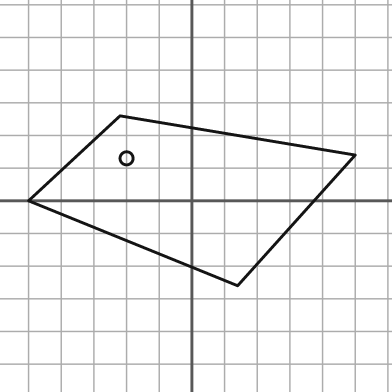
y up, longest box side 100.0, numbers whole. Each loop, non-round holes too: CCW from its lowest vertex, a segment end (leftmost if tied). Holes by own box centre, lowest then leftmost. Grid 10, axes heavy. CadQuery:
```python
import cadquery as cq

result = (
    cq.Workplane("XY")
    .moveTo(14.0, -26.0)
    .lineTo(50.0, 14.0)
    .lineTo(-22.0, 26.0)
    .lineTo(-50.0, 0.0)
    .close()
    .moveTo(-20.0, 13.0)
    .circle(2.0)
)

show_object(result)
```